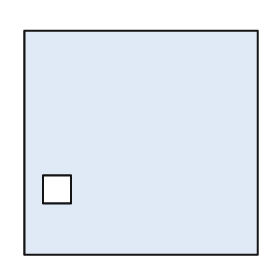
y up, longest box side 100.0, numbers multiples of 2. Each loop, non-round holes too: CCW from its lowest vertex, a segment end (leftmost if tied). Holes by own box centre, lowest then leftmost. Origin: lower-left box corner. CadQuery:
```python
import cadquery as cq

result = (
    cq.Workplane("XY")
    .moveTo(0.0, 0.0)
    .lineTo(100.0, 0.0)
    .lineTo(100.0, 96.0)
    .lineTo(0.0, 96.0)
    .close()
    .moveTo(8.0, 22.0)
    .lineTo(20.0, 22.0)
    .lineTo(20.0, 34.0)
    .lineTo(8.0, 34.0)
    .close()
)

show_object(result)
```